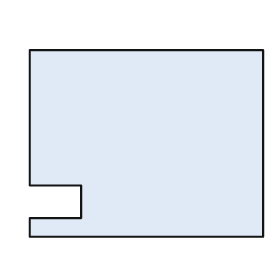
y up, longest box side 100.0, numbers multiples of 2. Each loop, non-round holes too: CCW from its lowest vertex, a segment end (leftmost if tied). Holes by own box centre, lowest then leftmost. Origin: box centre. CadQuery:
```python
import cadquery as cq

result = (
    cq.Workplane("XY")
    .moveTo(-50.0, -40.0)
    .lineTo(50.0, -40.0)
    .lineTo(50.0, 40.0)
    .lineTo(-50.0, 40.0)
    .lineTo(-50.0, -18.0)
    .lineTo(-28.0, -18.0)
    .lineTo(-28.0, -32.0)
    .lineTo(-50.0, -32.0)
    .close()
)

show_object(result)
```